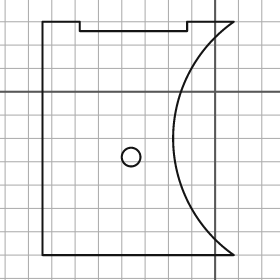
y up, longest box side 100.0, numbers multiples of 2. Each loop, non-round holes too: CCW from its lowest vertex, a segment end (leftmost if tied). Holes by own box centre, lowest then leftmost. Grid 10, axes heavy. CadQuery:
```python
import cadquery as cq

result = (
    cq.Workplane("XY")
    .moveTo(-74.0, -70.0)
    .lineTo(8.0, -70.0)
    .threePointArc((-18.0, -20.0), (8.0, 30.0))
    .lineTo(-12.0, 30.0)
    .lineTo(-12.0, 26.0)
    .lineTo(-58.0, 26.0)
    .lineTo(-58.0, 30.0)
    .lineTo(-74.0, 30.0)
    .close()
    .moveTo(-36.0, -28.0)
    .circle(4.0)
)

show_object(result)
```